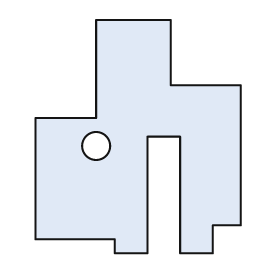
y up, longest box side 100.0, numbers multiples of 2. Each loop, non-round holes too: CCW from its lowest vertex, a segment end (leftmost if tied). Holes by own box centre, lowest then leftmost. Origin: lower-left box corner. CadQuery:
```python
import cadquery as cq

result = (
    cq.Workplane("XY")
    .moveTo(34.0, 0.0)
    .lineTo(48.0, 0.0)
    .lineTo(48.0, 50.0)
    .lineTo(62.0, 50.0)
    .lineTo(62.0, 0.0)
    .lineTo(76.0, 0.0)
    .lineTo(76.0, 12.0)
    .lineTo(88.0, 12.0)
    .lineTo(88.0, 72.0)
    .lineTo(58.0, 72.0)
    .lineTo(58.0, 100.0)
    .lineTo(26.0, 100.0)
    .lineTo(26.0, 58.0)
    .lineTo(0.0, 58.0)
    .lineTo(0.0, 6.0)
    .lineTo(34.0, 6.0)
    .close()
    .moveTo(26.0, 46.0)
    .circle(6.0)
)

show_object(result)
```